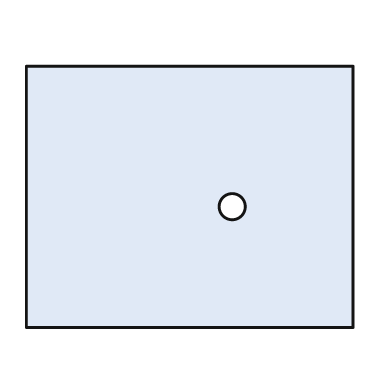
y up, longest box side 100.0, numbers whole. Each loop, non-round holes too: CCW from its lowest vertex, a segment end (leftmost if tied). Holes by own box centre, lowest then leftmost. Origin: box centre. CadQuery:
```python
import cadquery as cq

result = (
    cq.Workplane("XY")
    .moveTo(-50.0, -40.0)
    .lineTo(50.0, -40.0)
    .lineTo(50.0, 40.0)
    .lineTo(-50.0, 40.0)
    .close()
    .moveTo(13.0, -3.0)
    .circle(4.0)
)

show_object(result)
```